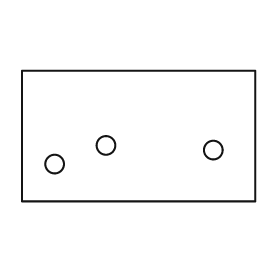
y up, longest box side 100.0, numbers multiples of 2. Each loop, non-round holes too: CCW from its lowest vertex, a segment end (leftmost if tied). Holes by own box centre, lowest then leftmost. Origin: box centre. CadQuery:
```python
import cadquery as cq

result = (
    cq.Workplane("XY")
    .moveTo(-50.0, -28.0)
    .lineTo(50.0, -28.0)
    .lineTo(50.0, 28.0)
    .lineTo(-50.0, 28.0)
    .close()
    .moveTo(-36.0, -12.0)
    .circle(4.0)
    .moveTo(32.0, -6.0)
    .circle(4.0)
    .moveTo(-14.0, -4.0)
    .circle(4.0)
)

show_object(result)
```